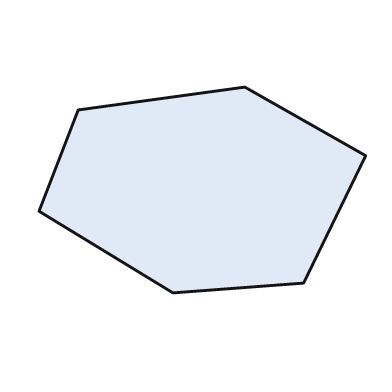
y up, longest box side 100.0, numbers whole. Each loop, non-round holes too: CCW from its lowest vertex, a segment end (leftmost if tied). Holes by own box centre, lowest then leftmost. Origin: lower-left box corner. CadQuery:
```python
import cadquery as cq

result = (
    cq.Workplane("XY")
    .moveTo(41.0, 0.0)
    .lineTo(81.0, 3.0)
    .lineTo(100.0, 42.0)
    .lineTo(63.0, 63.0)
    .lineTo(12.0, 56.0)
    .lineTo(0.0, 25.0)
    .close()
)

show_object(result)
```